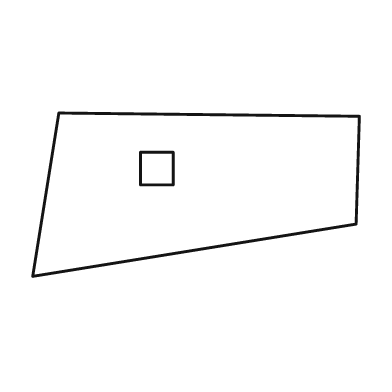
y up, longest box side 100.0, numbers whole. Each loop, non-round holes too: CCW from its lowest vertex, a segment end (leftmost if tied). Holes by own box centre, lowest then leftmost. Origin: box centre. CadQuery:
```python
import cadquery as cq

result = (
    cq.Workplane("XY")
    .moveTo(-50.0, -25.0)
    .lineTo(49.0, -9.0)
    .lineTo(50.0, 24.0)
    .lineTo(-42.0, 25.0)
    .close()
    .moveTo(-17.0, 3.0)
    .lineTo(-7.0, 3.0)
    .lineTo(-7.0, 13.0)
    .lineTo(-17.0, 13.0)
    .close()
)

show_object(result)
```